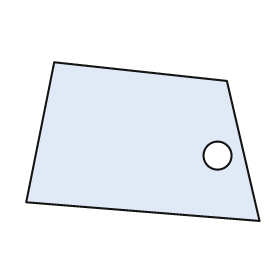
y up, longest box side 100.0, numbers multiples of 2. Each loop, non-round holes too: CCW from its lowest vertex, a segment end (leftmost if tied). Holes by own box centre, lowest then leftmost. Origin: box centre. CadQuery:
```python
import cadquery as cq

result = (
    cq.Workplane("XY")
    .moveTo(50.0, -34.0)
    .lineTo(36.0, 26.0)
    .lineTo(-38.0, 34.0)
    .lineTo(-50.0, -26.0)
    .close()
    .moveTo(32.0, -6.0)
    .circle(6.0)
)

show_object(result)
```